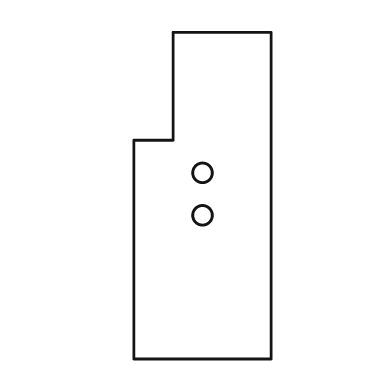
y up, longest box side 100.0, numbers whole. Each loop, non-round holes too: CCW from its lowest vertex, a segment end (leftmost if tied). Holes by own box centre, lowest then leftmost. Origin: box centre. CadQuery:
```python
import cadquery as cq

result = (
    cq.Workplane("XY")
    .moveTo(-21.0, -50.0)
    .lineTo(21.0, -50.0)
    .lineTo(21.0, 50.0)
    .lineTo(-9.0, 50.0)
    .lineTo(-9.0, 17.0)
    .lineTo(-21.0, 17.0)
    .close()
    .moveTo(0.0, -6.0)
    .circle(3.0)
    .moveTo(0.0, 7.0)
    .circle(3.0)
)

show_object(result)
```